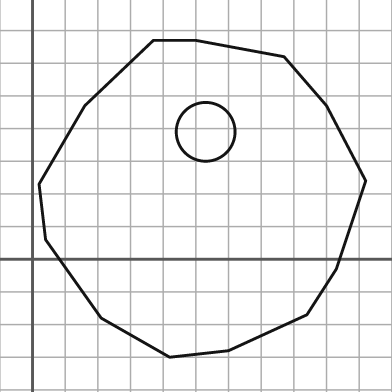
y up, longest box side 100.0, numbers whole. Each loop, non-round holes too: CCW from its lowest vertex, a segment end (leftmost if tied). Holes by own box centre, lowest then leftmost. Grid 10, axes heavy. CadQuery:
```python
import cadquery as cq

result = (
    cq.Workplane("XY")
    .moveTo(42.0, -30.0)
    .lineTo(60.0, -28.0)
    .lineTo(84.0, -17.0)
    .lineTo(93.0, -3.0)
    .lineTo(102.0, 24.0)
    .lineTo(90.0, 47.0)
    .lineTo(77.0, 62.0)
    .lineTo(50.0, 67.0)
    .lineTo(37.0, 67.0)
    .lineTo(16.0, 47.0)
    .lineTo(2.0, 23.0)
    .lineTo(4.0, 6.0)
    .lineTo(21.0, -18.0)
    .close()
    .moveTo(53.0, 39.0)
    .circle(9.0)
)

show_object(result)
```